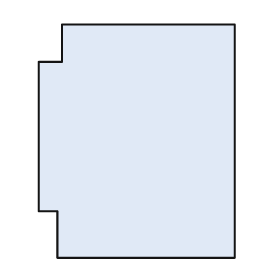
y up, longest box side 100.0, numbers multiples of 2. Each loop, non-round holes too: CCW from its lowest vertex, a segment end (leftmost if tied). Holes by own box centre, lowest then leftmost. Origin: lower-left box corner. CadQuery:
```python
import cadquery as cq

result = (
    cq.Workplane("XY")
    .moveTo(8.0, 0.0)
    .lineTo(84.0, 0.0)
    .lineTo(84.0, 100.0)
    .lineTo(10.0, 100.0)
    .lineTo(10.0, 84.0)
    .lineTo(0.0, 84.0)
    .lineTo(0.0, 20.0)
    .lineTo(8.0, 20.0)
    .close()
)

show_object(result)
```